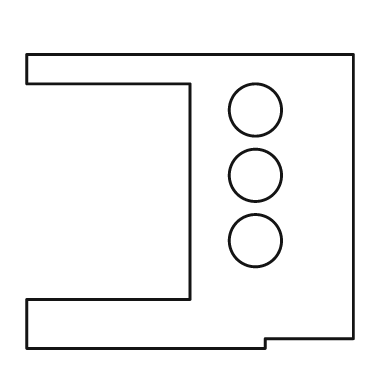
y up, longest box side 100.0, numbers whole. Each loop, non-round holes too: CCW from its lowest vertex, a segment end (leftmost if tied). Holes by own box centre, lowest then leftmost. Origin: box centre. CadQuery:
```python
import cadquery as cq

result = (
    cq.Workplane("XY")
    .moveTo(-50.0, -45.0)
    .lineTo(23.0, -45.0)
    .lineTo(23.0, -42.0)
    .lineTo(50.0, -42.0)
    .lineTo(50.0, 45.0)
    .lineTo(-50.0, 45.0)
    .lineTo(-50.0, 36.0)
    .lineTo(0.0, 36.0)
    .lineTo(0.0, -30.0)
    .lineTo(-50.0, -30.0)
    .close()
    .moveTo(20.0, -12.0)
    .circle(8.0)
    .moveTo(20.0, 8.0)
    .circle(8.0)
    .moveTo(20.0, 28.0)
    .circle(8.0)
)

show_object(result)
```